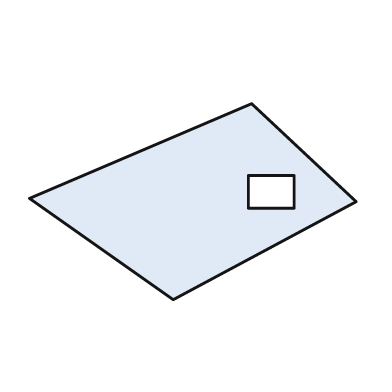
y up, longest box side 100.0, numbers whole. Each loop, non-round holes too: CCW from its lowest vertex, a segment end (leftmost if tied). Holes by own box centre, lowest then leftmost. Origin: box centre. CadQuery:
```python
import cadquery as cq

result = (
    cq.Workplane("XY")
    .moveTo(-6.0, -30.0)
    .lineTo(50.0, 0.0)
    .lineTo(18.0, 30.0)
    .lineTo(-50.0, 1.0)
    .close()
    .moveTo(17.0, -2.0)
    .lineTo(31.0, -2.0)
    .lineTo(31.0, 8.0)
    .lineTo(17.0, 8.0)
    .close()
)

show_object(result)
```